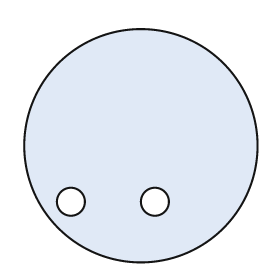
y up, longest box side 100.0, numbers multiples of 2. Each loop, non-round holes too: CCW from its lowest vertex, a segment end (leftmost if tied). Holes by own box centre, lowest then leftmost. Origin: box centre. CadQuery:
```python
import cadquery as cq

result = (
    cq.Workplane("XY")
    .moveTo(0.0, 0.0)
    .circle(50.0)
    .moveTo(-30.0, -24.0)
    .circle(6.0)
    .moveTo(6.0, -24.0)
    .circle(6.0)
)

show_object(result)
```